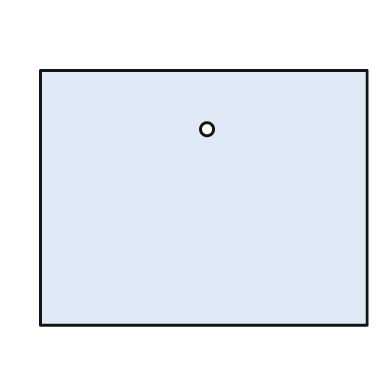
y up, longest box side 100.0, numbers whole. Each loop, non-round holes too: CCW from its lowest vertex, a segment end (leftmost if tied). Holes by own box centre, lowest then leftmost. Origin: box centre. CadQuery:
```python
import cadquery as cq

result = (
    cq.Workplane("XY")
    .moveTo(-50.0, -39.0)
    .lineTo(50.0, -39.0)
    .lineTo(50.0, 39.0)
    .lineTo(-50.0, 39.0)
    .close()
    .moveTo(1.0, 21.0)
    .circle(2.0)
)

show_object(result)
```